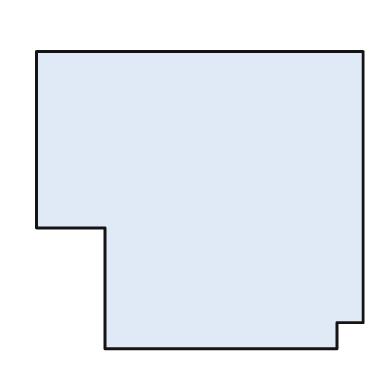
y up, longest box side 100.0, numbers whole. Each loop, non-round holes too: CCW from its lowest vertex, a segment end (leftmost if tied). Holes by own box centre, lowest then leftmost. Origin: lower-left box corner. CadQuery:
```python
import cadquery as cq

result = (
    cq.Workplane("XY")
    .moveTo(21.0, 0.0)
    .lineTo(92.0, 0.0)
    .lineTo(92.0, 8.0)
    .lineTo(100.0, 8.0)
    .lineTo(100.0, 91.0)
    .lineTo(0.0, 91.0)
    .lineTo(0.0, 37.0)
    .lineTo(21.0, 37.0)
    .close()
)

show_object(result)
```